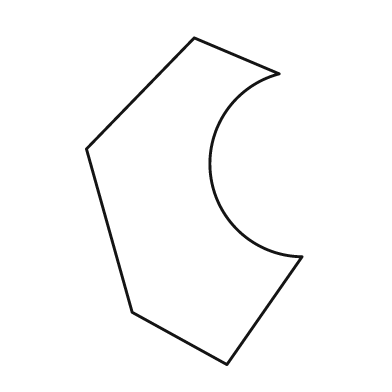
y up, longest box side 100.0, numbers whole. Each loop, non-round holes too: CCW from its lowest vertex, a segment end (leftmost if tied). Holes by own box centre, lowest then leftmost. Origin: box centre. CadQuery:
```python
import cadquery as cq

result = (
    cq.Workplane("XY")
    .moveTo(10.0, -50.0)
    .lineTo(33.0, -17.0)
    .threePointArc((5.0, 8.0), (26.0, 39.0))
    .lineTo(0.0, 50.0)
    .lineTo(-33.0, 16.0)
    .lineTo(-19.0, -34.0)
    .close()
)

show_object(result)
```